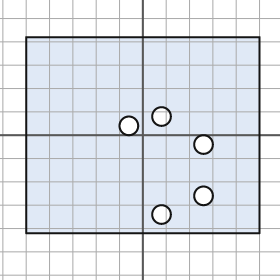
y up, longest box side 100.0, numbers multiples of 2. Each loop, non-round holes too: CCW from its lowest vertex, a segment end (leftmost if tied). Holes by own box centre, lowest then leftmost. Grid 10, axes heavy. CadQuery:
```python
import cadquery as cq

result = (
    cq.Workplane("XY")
    .moveTo(-50.0, -42.0)
    .lineTo(50.0, -42.0)
    .lineTo(50.0, 42.0)
    .lineTo(-50.0, 42.0)
    .close()
    .moveTo(8.0, -34.0)
    .circle(4.0)
    .moveTo(26.0, -26.0)
    .circle(4.0)
    .moveTo(26.0, -4.0)
    .circle(4.0)
    .moveTo(-6.0, 4.0)
    .circle(4.0)
    .moveTo(8.0, 8.0)
    .circle(4.0)
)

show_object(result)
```